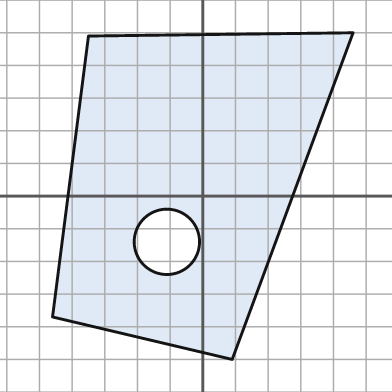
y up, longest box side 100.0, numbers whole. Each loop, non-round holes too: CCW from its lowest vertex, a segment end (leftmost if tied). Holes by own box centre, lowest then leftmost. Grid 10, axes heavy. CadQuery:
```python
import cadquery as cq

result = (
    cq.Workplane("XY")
    .moveTo(9.0, -50.0)
    .lineTo(46.0, 50.0)
    .lineTo(-35.0, 49.0)
    .lineTo(-46.0, -37.0)
    .close()
    .moveTo(-11.0, -14.0)
    .circle(10.0)
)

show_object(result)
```